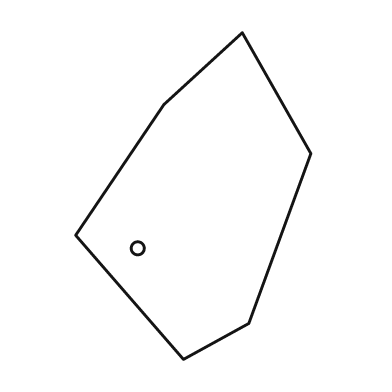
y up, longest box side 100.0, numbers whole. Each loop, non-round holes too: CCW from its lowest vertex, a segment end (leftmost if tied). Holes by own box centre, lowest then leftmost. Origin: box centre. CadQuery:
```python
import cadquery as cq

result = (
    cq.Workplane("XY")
    .moveTo(-3.0, -50.0)
    .lineTo(17.0, -39.0)
    .lineTo(36.0, 13.0)
    .lineTo(15.0, 50.0)
    .lineTo(-9.0, 28.0)
    .lineTo(-36.0, -12.0)
    .close()
    .moveTo(-17.0, -16.0)
    .circle(2.0)
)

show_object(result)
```